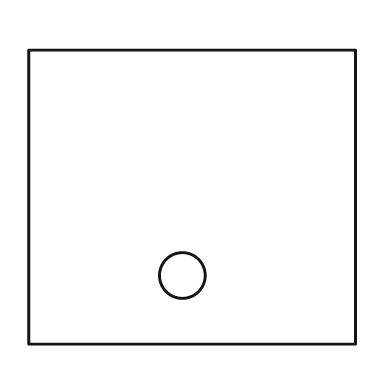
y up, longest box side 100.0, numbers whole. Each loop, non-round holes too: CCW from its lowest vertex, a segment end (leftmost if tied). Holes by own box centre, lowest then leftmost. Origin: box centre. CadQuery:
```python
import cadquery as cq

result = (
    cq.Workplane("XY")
    .moveTo(-50.0, -45.0)
    .lineTo(50.0, -45.0)
    .lineTo(50.0, 45.0)
    .lineTo(-50.0, 45.0)
    .close()
    .moveTo(-3.0, -24.0)
    .circle(7.0)
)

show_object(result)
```